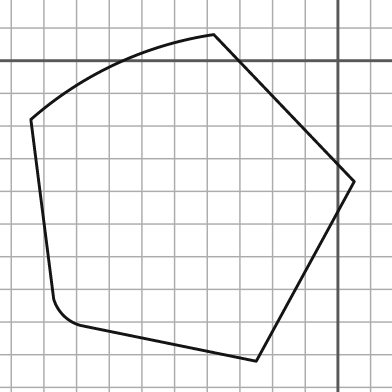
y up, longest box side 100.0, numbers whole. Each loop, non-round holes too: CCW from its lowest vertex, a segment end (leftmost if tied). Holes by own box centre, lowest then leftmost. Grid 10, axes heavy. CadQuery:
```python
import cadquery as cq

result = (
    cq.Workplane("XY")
    .moveTo(-25.0, -92.0)
    .lineTo(5.0, -37.0)
    .lineTo(-38.0, 8.0)
    .threePointArc((-68.0, -1.0), (-94.0, -18.0))
    .lineTo(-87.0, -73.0)
    .threePointArc((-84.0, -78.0), (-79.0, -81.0))
    .close()
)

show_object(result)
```